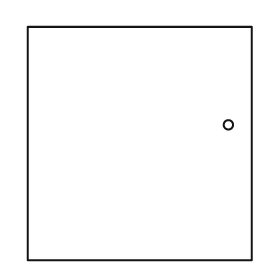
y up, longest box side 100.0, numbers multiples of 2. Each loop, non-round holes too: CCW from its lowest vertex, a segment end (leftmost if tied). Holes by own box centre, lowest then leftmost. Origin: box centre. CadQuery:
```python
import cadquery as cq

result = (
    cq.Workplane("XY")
    .moveTo(-48.0, -50.0)
    .lineTo(48.0, -50.0)
    .lineTo(48.0, 50.0)
    .lineTo(-48.0, 50.0)
    .close()
    .moveTo(38.0, 8.0)
    .circle(2.0)
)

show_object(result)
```